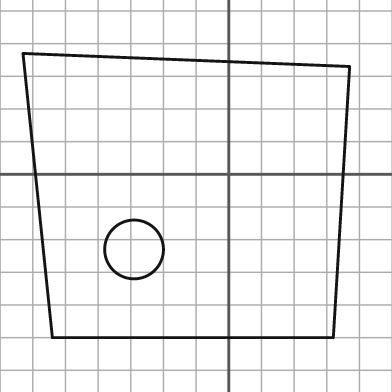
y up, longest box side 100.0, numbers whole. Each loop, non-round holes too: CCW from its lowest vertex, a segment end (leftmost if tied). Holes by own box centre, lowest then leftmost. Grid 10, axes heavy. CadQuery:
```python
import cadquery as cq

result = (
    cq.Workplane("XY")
    .moveTo(-54.0, -50.0)
    .lineTo(32.0, -50.0)
    .lineTo(37.0, 33.0)
    .lineTo(-63.0, 37.0)
    .close()
    .moveTo(-29.0, -23.0)
    .circle(9.0)
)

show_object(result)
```